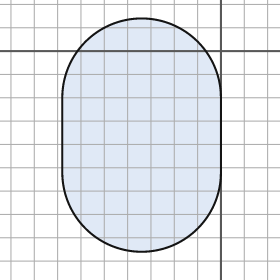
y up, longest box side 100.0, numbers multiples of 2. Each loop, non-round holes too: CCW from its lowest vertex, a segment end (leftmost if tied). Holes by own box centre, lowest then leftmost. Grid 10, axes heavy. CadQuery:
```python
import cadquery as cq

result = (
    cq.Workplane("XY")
    .moveTo(-68.0, -52.0)
    .threePointArc((-34.0, -86.0), (0.0, -52.0))
    .lineTo(0.0, -20.0)
    .threePointArc((-34.0, 14.0), (-68.0, -20.0))
    .close()
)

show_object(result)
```